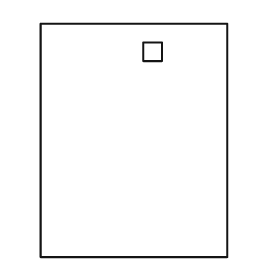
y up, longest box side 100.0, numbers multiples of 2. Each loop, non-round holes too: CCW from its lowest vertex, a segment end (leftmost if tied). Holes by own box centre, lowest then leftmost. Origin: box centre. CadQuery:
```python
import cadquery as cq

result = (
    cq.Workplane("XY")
    .moveTo(-40.0, -50.0)
    .lineTo(40.0, -50.0)
    .lineTo(40.0, 50.0)
    .lineTo(-40.0, 50.0)
    .close()
    .moveTo(4.0, 34.0)
    .lineTo(12.0, 34.0)
    .lineTo(12.0, 42.0)
    .lineTo(4.0, 42.0)
    .close()
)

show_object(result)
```